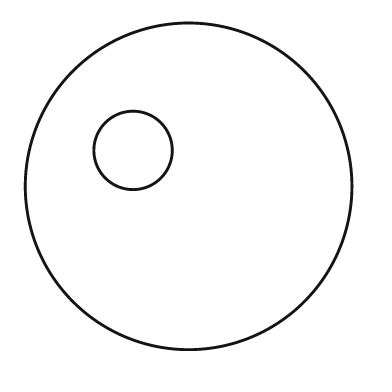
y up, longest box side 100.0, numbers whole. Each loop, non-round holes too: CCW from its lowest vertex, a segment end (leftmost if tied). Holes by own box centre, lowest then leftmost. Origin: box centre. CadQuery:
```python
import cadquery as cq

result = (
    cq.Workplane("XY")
    .moveTo(0.0, 0.0)
    .circle(50.0)
    .moveTo(-17.0, 11.0)
    .circle(12.0)
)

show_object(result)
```